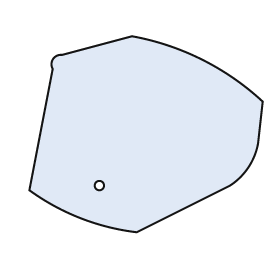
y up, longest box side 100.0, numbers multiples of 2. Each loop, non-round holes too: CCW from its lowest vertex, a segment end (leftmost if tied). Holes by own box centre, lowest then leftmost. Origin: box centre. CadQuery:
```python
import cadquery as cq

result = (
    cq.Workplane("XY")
    .moveTo(-4.0, -42.0)
    .lineTo(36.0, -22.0)
    .threePointArc((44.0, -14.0), (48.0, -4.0))
    .lineTo(50.0, 14.0)
    .threePointArc((24.0, 32.0), (-6.0, 42.0))
    .lineTo(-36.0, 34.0)
    .threePointArc((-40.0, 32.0), (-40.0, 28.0))
    .lineTo(-50.0, -24.0)
    .threePointArc((-28.0, -36.0), (-4.0, -42.0))
    .close()
    .moveTo(-20.0, -22.0)
    .circle(2.0)
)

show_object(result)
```